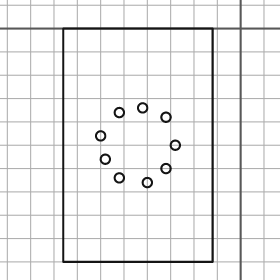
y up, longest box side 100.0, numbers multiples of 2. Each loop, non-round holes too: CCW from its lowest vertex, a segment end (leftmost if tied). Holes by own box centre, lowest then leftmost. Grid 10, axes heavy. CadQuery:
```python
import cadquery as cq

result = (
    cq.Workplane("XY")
    .moveTo(-76.0, -100.0)
    .lineTo(-12.0, -100.0)
    .lineTo(-12.0, 0.0)
    .lineTo(-76.0, 0.0)
    .close()
    .moveTo(-40.0, -66.0)
    .circle(2.0)
    .moveTo(-52.0, -64.0)
    .circle(2.0)
    .moveTo(-32.0, -60.0)
    .circle(2.0)
    .moveTo(-58.0, -56.0)
    .circle(2.0)
    .moveTo(-28.0, -50.0)
    .circle(2.0)
    .moveTo(-60.0, -46.0)
    .circle(2.0)
    .moveTo(-32.0, -38.0)
    .circle(2.0)
    .moveTo(-52.0, -36.0)
    .circle(2.0)
    .moveTo(-42.0, -34.0)
    .circle(2.0)
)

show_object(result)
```